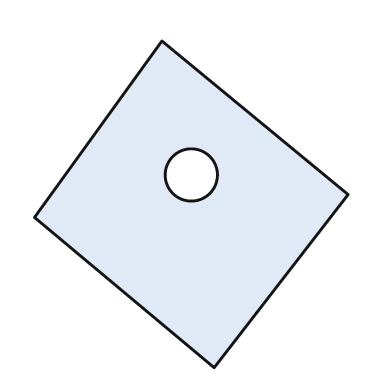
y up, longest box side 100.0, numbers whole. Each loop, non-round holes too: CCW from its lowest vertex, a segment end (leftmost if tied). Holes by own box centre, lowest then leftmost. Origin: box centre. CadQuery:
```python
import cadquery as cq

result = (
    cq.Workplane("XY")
    .moveTo(7.0, -50.0)
    .lineTo(48.0, 3.0)
    .lineTo(-9.0, 50.0)
    .lineTo(-48.0, -4.0)
    .close()
    .moveTo(0.0, 9.0)
    .circle(8.0)
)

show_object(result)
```